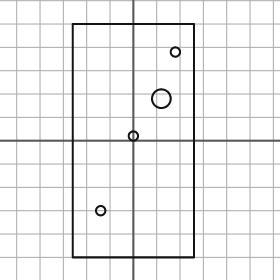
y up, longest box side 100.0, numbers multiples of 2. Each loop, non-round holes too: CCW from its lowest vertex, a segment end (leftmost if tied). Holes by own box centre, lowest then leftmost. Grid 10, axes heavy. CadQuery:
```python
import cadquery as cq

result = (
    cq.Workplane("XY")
    .moveTo(-26.0, -50.0)
    .lineTo(26.0, -50.0)
    .lineTo(26.0, 50.0)
    .lineTo(-26.0, 50.0)
    .close()
    .moveTo(-14.0, -30.0)
    .circle(2.0)
    .moveTo(0.0, 2.0)
    .circle(2.0)
    .moveTo(12.0, 18.0)
    .circle(4.0)
    .moveTo(18.0, 38.0)
    .circle(2.0)
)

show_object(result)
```